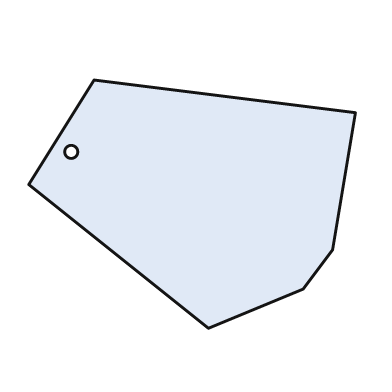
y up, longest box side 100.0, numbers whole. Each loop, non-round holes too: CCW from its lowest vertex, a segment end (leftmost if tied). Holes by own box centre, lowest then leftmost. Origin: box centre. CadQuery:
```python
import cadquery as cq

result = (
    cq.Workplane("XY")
    .moveTo(5.0, -38.0)
    .lineTo(34.0, -26.0)
    .lineTo(43.0, -14.0)
    .lineTo(50.0, 28.0)
    .lineTo(-30.0, 38.0)
    .lineTo(-50.0, 6.0)
    .close()
    .moveTo(-37.0, 16.0)
    .circle(2.0)
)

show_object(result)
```